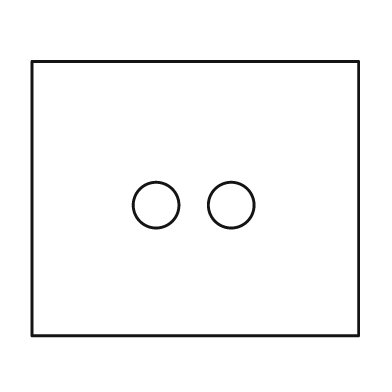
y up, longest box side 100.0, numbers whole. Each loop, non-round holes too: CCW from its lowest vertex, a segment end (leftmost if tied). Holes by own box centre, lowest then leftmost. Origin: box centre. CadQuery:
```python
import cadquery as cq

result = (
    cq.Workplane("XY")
    .moveTo(-50.0, -42.0)
    .lineTo(50.0, -42.0)
    .lineTo(50.0, 42.0)
    .lineTo(-50.0, 42.0)
    .close()
    .moveTo(-12.0, -2.0)
    .circle(7.0)
    .moveTo(11.0, -2.0)
    .circle(7.0)
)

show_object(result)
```